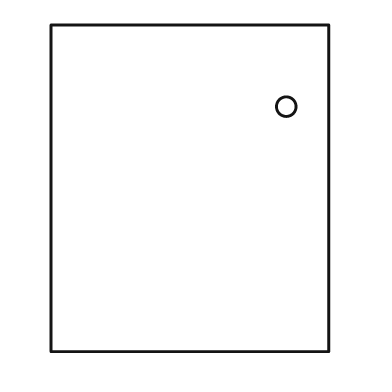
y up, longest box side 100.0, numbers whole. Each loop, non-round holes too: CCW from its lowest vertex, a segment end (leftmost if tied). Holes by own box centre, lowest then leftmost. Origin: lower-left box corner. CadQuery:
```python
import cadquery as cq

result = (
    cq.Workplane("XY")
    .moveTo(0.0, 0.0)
    .lineTo(85.0, 0.0)
    .lineTo(85.0, 100.0)
    .lineTo(0.0, 100.0)
    .close()
    .moveTo(72.0, 75.0)
    .circle(3.0)
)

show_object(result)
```